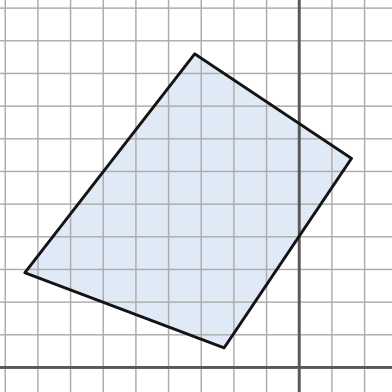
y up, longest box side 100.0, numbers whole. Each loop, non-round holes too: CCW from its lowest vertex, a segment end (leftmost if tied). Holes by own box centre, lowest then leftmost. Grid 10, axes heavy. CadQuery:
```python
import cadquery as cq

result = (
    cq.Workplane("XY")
    .moveTo(-23.0, 6.0)
    .lineTo(16.0, 64.0)
    .lineTo(-32.0, 96.0)
    .lineTo(-84.0, 29.0)
    .close()
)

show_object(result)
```